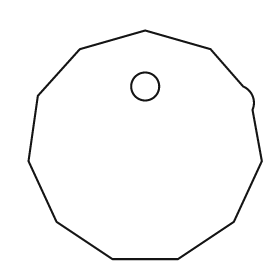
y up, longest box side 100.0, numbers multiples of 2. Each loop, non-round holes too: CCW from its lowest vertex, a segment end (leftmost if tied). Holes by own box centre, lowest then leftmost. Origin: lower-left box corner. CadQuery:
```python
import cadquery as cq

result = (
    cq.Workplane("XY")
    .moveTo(36.0, 0.0)
    .lineTo(64.0, 0.0)
    .lineTo(88.0, 16.0)
    .lineTo(100.0, 42.0)
    .lineTo(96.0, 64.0)
    .threePointArc((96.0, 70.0), (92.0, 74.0))
    .lineTo(78.0, 90.0)
    .lineTo(50.0, 98.0)
    .lineTo(22.0, 90.0)
    .lineTo(4.0, 70.0)
    .lineTo(0.0, 42.0)
    .lineTo(12.0, 16.0)
    .close()
    .moveTo(50.0, 74.0)
    .circle(6.0)
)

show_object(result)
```